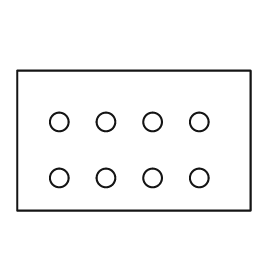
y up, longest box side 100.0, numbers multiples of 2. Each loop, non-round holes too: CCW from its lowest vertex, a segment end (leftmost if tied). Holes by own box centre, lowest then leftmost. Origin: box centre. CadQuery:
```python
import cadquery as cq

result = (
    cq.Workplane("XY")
    .moveTo(-50.0, -30.0)
    .lineTo(50.0, -30.0)
    .lineTo(50.0, 30.0)
    .lineTo(-50.0, 30.0)
    .close()
    .moveTo(-32.0, -16.0)
    .circle(4.0)
    .moveTo(-12.0, -16.0)
    .circle(4.0)
    .moveTo(8.0, -16.0)
    .circle(4.0)
    .moveTo(28.0, -16.0)
    .circle(4.0)
    .moveTo(-32.0, 8.0)
    .circle(4.0)
    .moveTo(-12.0, 8.0)
    .circle(4.0)
    .moveTo(8.0, 8.0)
    .circle(4.0)
    .moveTo(28.0, 8.0)
    .circle(4.0)
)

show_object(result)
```